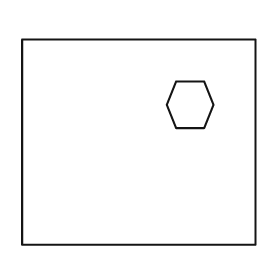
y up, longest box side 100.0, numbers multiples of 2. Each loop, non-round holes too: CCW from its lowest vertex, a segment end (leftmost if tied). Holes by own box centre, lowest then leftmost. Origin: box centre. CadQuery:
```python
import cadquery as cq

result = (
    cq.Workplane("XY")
    .moveTo(-50.0, -44.0)
    .lineTo(50.0, -44.0)
    .lineTo(50.0, 44.0)
    .lineTo(-50.0, 44.0)
    .close()
    .moveTo(16.0, 6.0)
    .lineTo(28.0, 6.0)
    .lineTo(32.0, 16.0)
    .lineTo(28.0, 26.0)
    .lineTo(16.0, 26.0)
    .lineTo(12.0, 16.0)
    .close()
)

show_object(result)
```